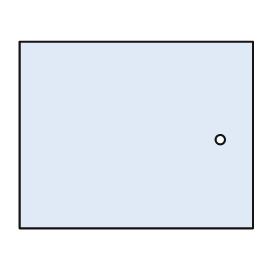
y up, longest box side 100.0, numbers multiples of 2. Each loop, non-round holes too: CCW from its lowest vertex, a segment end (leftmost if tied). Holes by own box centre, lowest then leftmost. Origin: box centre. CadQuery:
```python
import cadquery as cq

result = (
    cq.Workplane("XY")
    .moveTo(-50.0, -40.0)
    .lineTo(50.0, -40.0)
    .lineTo(50.0, 40.0)
    .lineTo(-50.0, 40.0)
    .close()
    .moveTo(36.0, -2.0)
    .circle(2.0)
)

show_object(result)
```